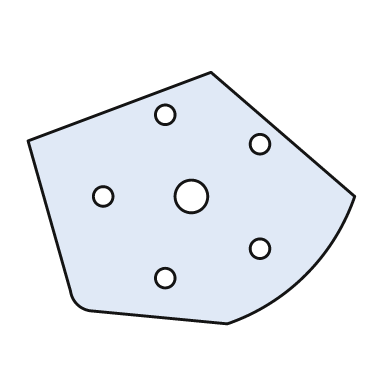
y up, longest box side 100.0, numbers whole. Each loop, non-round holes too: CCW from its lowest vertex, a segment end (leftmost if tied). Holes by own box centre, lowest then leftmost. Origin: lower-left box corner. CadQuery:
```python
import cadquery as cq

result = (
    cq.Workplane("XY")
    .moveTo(61.0, 0.0)
    .threePointArc((85.0, 15.0), (100.0, 39.0))
    .lineTo(56.0, 77.0)
    .lineTo(0.0, 56.0)
    .lineTo(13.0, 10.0)
    .threePointArc((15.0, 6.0), (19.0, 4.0))
    .close()
    .moveTo(42.0, 14.0)
    .circle(3.0)
    .moveTo(71.0, 23.0)
    .circle(3.0)
    .moveTo(23.0, 39.0)
    .circle(3.0)
    .moveTo(50.0, 39.0)
    .circle(5.0)
    .moveTo(71.0, 55.0)
    .circle(3.0)
    .moveTo(42.0, 64.0)
    .circle(3.0)
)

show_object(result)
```